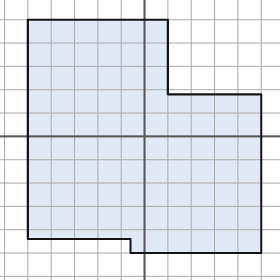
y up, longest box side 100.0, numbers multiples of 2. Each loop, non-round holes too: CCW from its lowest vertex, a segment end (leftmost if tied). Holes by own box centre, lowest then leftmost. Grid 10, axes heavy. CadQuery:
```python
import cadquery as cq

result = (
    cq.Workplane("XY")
    .moveTo(-6.0, -50.0)
    .lineTo(50.0, -50.0)
    .lineTo(50.0, 18.0)
    .lineTo(10.0, 18.0)
    .lineTo(10.0, 50.0)
    .lineTo(-50.0, 50.0)
    .lineTo(-50.0, -44.0)
    .lineTo(-6.0, -44.0)
    .close()
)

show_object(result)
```